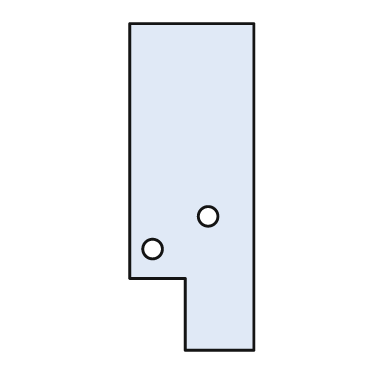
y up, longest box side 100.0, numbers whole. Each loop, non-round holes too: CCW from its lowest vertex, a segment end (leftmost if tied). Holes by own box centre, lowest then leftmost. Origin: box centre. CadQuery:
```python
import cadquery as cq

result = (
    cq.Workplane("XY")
    .moveTo(-2.0, -50.0)
    .lineTo(19.0, -50.0)
    .lineTo(19.0, 50.0)
    .lineTo(-19.0, 50.0)
    .lineTo(-19.0, -28.0)
    .lineTo(-2.0, -28.0)
    .close()
    .moveTo(-12.0, -19.0)
    .circle(3.0)
    .moveTo(5.0, -9.0)
    .circle(3.0)
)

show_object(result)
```